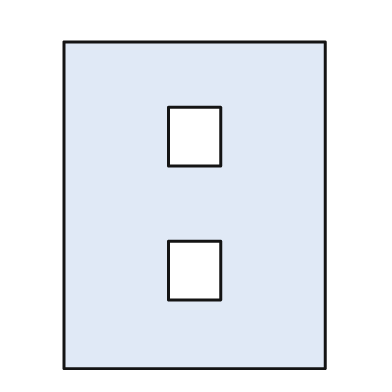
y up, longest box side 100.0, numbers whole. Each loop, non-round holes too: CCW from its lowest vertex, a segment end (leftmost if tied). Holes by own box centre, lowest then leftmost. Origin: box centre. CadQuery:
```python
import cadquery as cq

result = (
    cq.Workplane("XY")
    .moveTo(-40.0, -50.0)
    .lineTo(40.0, -50.0)
    .lineTo(40.0, 50.0)
    .lineTo(-40.0, 50.0)
    .close()
    .moveTo(-8.0, -29.0)
    .lineTo(8.0, -29.0)
    .lineTo(8.0, -11.0)
    .lineTo(-8.0, -11.0)
    .close()
    .moveTo(-8.0, 12.0)
    .lineTo(8.0, 12.0)
    .lineTo(8.0, 30.0)
    .lineTo(-8.0, 30.0)
    .close()
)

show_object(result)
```